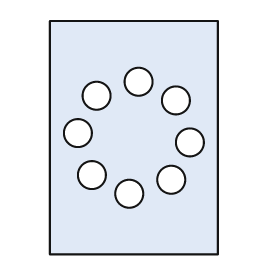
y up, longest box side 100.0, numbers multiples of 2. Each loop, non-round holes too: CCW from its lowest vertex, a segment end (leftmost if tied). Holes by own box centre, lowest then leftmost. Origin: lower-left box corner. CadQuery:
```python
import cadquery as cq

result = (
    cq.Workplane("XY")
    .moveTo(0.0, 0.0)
    .lineTo(72.0, 0.0)
    .lineTo(72.0, 100.0)
    .lineTo(0.0, 100.0)
    .close()
    .moveTo(34.0, 26.0)
    .circle(6.0)
    .moveTo(52.0, 32.0)
    .circle(6.0)
    .moveTo(18.0, 34.0)
    .circle(6.0)
    .moveTo(60.0, 48.0)
    .circle(6.0)
    .moveTo(12.0, 52.0)
    .circle(6.0)
    .moveTo(54.0, 66.0)
    .circle(6.0)
    .moveTo(20.0, 68.0)
    .circle(6.0)
    .moveTo(38.0, 74.0)
    .circle(6.0)
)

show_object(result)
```